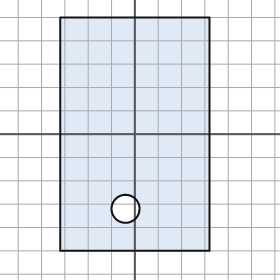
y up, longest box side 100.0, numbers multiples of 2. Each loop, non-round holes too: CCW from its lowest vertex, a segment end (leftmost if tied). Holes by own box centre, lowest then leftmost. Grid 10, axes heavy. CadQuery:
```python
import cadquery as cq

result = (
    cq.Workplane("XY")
    .moveTo(-32.0, -50.0)
    .lineTo(32.0, -50.0)
    .lineTo(32.0, 50.0)
    .lineTo(-32.0, 50.0)
    .close()
    .moveTo(-4.0, -32.0)
    .circle(6.0)
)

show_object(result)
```